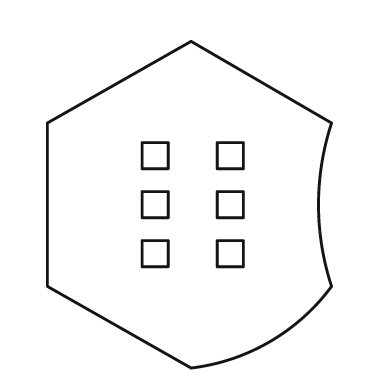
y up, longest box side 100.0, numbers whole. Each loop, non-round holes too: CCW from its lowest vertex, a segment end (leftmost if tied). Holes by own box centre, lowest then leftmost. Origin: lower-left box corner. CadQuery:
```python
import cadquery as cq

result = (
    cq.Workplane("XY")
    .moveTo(44.0, 0.0)
    .threePointArc((68.0, 8.0), (87.0, 25.0))
    .threePointArc((83.0, 50.0), (87.0, 75.0))
    .lineTo(44.0, 100.0)
    .lineTo(0.0, 75.0)
    .lineTo(0.0, 25.0)
    .close()
    .moveTo(29.0, 31.0)
    .lineTo(37.0, 31.0)
    .lineTo(37.0, 39.0)
    .lineTo(29.0, 39.0)
    .close()
    .moveTo(52.0, 31.0)
    .lineTo(60.0, 31.0)
    .lineTo(60.0, 39.0)
    .lineTo(52.0, 39.0)
    .close()
    .moveTo(29.0, 46.0)
    .lineTo(37.0, 46.0)
    .lineTo(37.0, 54.0)
    .lineTo(29.0, 54.0)
    .close()
    .moveTo(52.0, 46.0)
    .lineTo(60.0, 46.0)
    .lineTo(60.0, 54.0)
    .lineTo(52.0, 54.0)
    .close()
    .moveTo(29.0, 61.0)
    .lineTo(37.0, 61.0)
    .lineTo(37.0, 69.0)
    .lineTo(29.0, 69.0)
    .close()
    .moveTo(52.0, 61.0)
    .lineTo(60.0, 61.0)
    .lineTo(60.0, 69.0)
    .lineTo(52.0, 69.0)
    .close()
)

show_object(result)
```